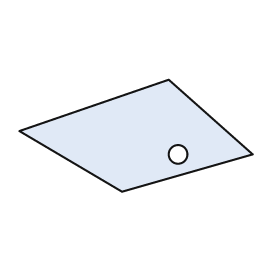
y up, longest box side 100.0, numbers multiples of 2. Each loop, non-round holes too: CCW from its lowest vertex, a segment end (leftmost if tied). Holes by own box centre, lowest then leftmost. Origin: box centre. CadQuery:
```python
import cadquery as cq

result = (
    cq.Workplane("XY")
    .moveTo(-6.0, -24.0)
    .lineTo(50.0, -8.0)
    .lineTo(14.0, 24.0)
    .lineTo(-50.0, 2.0)
    .close()
    .moveTo(18.0, -8.0)
    .circle(4.0)
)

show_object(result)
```